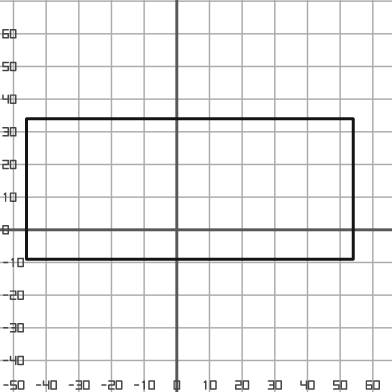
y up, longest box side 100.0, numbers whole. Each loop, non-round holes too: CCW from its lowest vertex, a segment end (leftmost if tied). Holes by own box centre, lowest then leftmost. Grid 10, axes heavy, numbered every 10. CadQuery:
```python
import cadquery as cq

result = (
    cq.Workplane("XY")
    .moveTo(-46.0, -9.0)
    .lineTo(54.0, -9.0)
    .lineTo(54.0, 34.0)
    .lineTo(-46.0, 34.0)
    .close()
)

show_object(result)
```